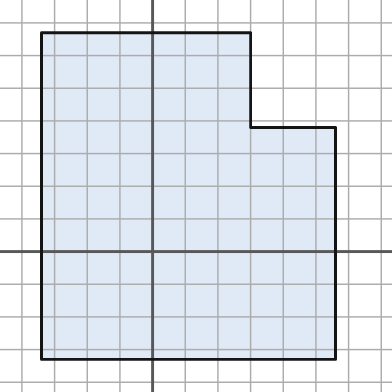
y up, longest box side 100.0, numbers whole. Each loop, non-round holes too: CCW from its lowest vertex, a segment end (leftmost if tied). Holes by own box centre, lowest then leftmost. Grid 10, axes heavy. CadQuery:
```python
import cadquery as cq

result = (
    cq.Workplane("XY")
    .moveTo(-34.0, -33.0)
    .lineTo(56.0, -33.0)
    .lineTo(56.0, 38.0)
    .lineTo(30.0, 38.0)
    .lineTo(30.0, 67.0)
    .lineTo(-34.0, 67.0)
    .close()
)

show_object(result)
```